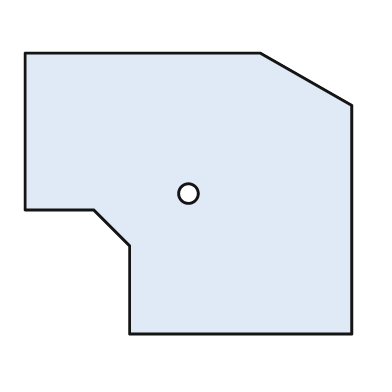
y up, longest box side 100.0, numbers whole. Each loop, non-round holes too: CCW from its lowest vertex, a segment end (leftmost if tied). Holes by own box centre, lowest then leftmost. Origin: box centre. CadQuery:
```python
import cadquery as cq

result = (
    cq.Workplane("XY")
    .moveTo(-18.0, -43.0)
    .lineTo(50.0, -43.0)
    .lineTo(50.0, 27.0)
    .lineTo(22.0, 43.0)
    .lineTo(-50.0, 43.0)
    .lineTo(-50.0, -5.0)
    .lineTo(-29.0, -5.0)
    .lineTo(-18.0, -16.0)
    .close()
    .moveTo(0.0, 0.0)
    .circle(3.0)
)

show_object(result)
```